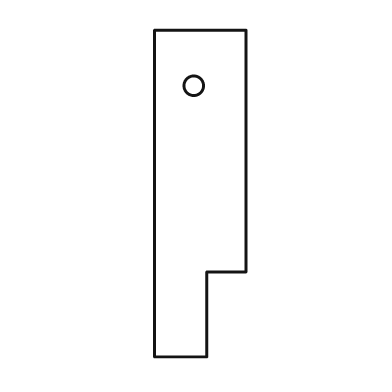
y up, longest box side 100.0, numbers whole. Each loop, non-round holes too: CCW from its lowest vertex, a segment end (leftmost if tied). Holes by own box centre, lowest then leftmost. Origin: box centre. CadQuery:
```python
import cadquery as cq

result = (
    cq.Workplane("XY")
    .moveTo(-14.0, -50.0)
    .lineTo(2.0, -50.0)
    .lineTo(2.0, -24.0)
    .lineTo(14.0, -24.0)
    .lineTo(14.0, 50.0)
    .lineTo(-14.0, 50.0)
    .close()
    .moveTo(-2.0, 33.0)
    .circle(3.0)
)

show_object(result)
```